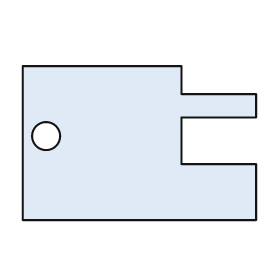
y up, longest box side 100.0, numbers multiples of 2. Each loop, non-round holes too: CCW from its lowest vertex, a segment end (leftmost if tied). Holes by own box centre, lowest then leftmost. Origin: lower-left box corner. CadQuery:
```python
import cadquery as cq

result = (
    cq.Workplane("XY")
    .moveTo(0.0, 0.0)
    .lineTo(100.0, 0.0)
    .lineTo(100.0, 24.0)
    .lineTo(68.0, 24.0)
    .lineTo(68.0, 44.0)
    .lineTo(100.0, 44.0)
    .lineTo(100.0, 54.0)
    .lineTo(68.0, 54.0)
    .lineTo(68.0, 66.0)
    .lineTo(0.0, 66.0)
    .close()
    .moveTo(10.0, 36.0)
    .circle(6.0)
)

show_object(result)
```